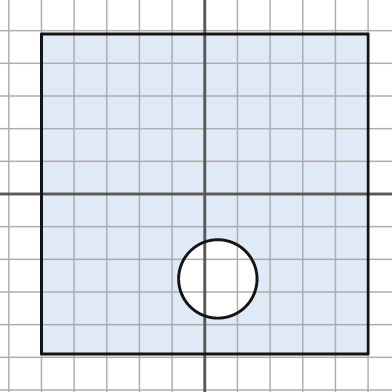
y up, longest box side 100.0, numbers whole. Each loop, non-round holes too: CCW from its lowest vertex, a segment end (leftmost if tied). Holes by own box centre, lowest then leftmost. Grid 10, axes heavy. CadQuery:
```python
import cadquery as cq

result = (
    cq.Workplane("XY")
    .moveTo(-50.0, -49.0)
    .lineTo(50.0, -49.0)
    .lineTo(50.0, 49.0)
    .lineTo(-50.0, 49.0)
    .close()
    .moveTo(4.0, -26.0)
    .circle(12.0)
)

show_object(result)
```